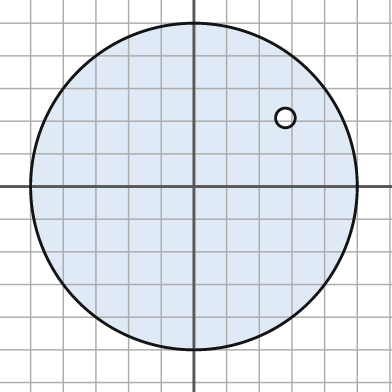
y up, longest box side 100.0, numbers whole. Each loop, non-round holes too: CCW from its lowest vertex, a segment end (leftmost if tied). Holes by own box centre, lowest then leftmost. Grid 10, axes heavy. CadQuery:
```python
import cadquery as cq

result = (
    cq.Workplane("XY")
    .moveTo(0.0, 0.0)
    .circle(50.0)
    .moveTo(28.0, 21.0)
    .circle(3.0)
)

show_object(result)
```